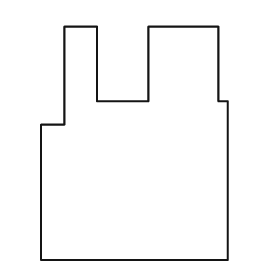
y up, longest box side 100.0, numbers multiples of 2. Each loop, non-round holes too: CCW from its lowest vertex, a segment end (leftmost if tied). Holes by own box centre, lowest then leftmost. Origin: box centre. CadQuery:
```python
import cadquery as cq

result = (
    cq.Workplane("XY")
    .moveTo(-40.0, -50.0)
    .lineTo(40.0, -50.0)
    .lineTo(40.0, 18.0)
    .lineTo(36.0, 18.0)
    .lineTo(36.0, 50.0)
    .lineTo(6.0, 50.0)
    .lineTo(6.0, 18.0)
    .lineTo(-16.0, 18.0)
    .lineTo(-16.0, 50.0)
    .lineTo(-30.0, 50.0)
    .lineTo(-30.0, 8.0)
    .lineTo(-40.0, 8.0)
    .close()
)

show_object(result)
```